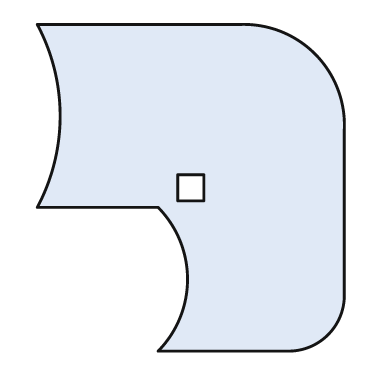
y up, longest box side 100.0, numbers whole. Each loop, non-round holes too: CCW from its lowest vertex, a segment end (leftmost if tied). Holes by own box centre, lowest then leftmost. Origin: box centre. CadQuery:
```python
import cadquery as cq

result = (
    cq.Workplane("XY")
    .moveTo(-10.0, -50.0)
    .lineTo(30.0, -50.0)
    .threePointArc((42.0, -45.0), (47.0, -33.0))
    .lineTo(47.0, 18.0)
    .threePointArc((38.0, 41.0), (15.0, 50.0))
    .lineTo(-47.0, 50.0)
    .threePointArc((-40.0, 22.0), (-47.0, -6.0))
    .lineTo(-10.0, -6.0)
    .threePointArc((-1.0, -28.0), (-10.0, -50.0))
    .close()
    .moveTo(-4.0, -4.0)
    .lineTo(4.0, -4.0)
    .lineTo(4.0, 4.0)
    .lineTo(-4.0, 4.0)
    .close()
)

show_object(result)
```